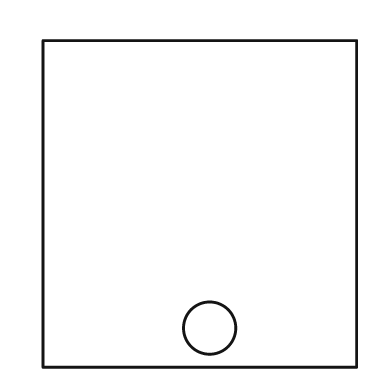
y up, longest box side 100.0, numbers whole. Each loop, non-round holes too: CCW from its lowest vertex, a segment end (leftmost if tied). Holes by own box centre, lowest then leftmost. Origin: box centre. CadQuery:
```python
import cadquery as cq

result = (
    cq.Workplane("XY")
    .moveTo(-48.0, -50.0)
    .lineTo(48.0, -50.0)
    .lineTo(48.0, 50.0)
    .lineTo(-48.0, 50.0)
    .close()
    .moveTo(3.0, -38.0)
    .circle(8.0)
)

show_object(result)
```